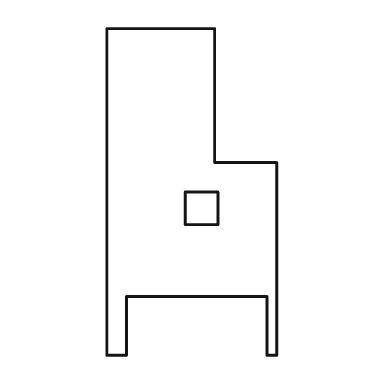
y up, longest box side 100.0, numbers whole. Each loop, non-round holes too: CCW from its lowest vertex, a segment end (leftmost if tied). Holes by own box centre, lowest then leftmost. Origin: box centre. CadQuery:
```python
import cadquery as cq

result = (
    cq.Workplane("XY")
    .moveTo(-26.0, -50.0)
    .lineTo(-20.0, -50.0)
    .lineTo(-20.0, -32.0)
    .lineTo(23.0, -32.0)
    .lineTo(23.0, -50.0)
    .lineTo(26.0, -50.0)
    .lineTo(26.0, 9.0)
    .lineTo(7.0, 9.0)
    .lineTo(7.0, 50.0)
    .lineTo(-26.0, 50.0)
    .close()
    .moveTo(-2.0, -10.0)
    .lineTo(8.0, -10.0)
    .lineTo(8.0, 0.0)
    .lineTo(-2.0, 0.0)
    .close()
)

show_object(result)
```